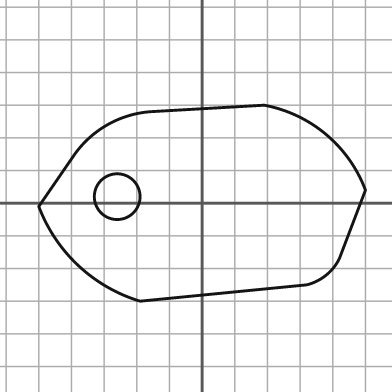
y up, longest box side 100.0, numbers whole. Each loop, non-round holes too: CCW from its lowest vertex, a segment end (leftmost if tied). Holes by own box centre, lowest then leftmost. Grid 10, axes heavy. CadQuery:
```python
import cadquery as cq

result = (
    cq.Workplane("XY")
    .moveTo(-19.0, -30.0)
    .lineTo(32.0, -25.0)
    .threePointArc((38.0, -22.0), (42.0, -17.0))
    .lineTo(50.0, 4.0)
    .threePointArc((38.0, 21.0), (19.0, 30.0))
    .lineTo(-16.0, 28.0)
    .threePointArc((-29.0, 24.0), (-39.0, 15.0))
    .lineTo(-50.0, -1.0)
    .threePointArc((-38.0, -19.0), (-19.0, -30.0))
    .close()
    .moveTo(-26.0, 2.0)
    .circle(7.0)
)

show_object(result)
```